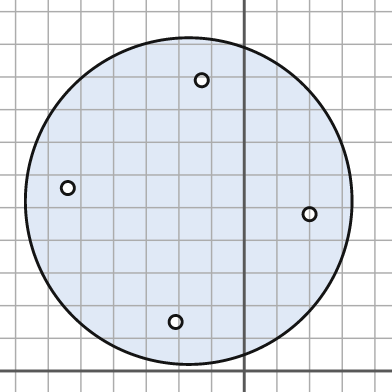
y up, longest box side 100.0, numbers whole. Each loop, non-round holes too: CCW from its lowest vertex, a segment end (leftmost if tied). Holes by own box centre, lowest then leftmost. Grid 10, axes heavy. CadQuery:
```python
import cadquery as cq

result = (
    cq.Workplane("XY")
    .moveTo(-17.0, 52.0)
    .circle(50.0)
    .moveTo(-21.0, 15.0)
    .circle(2.0)
    .moveTo(20.0, 48.0)
    .circle(2.0)
    .moveTo(-54.0, 56.0)
    .circle(2.0)
    .moveTo(-13.0, 89.0)
    .circle(2.0)
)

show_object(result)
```